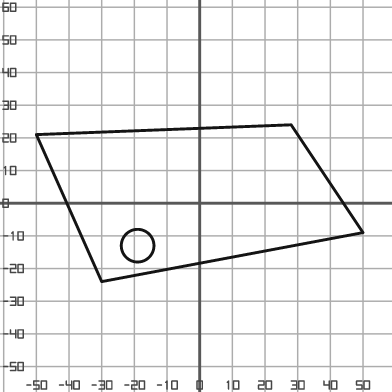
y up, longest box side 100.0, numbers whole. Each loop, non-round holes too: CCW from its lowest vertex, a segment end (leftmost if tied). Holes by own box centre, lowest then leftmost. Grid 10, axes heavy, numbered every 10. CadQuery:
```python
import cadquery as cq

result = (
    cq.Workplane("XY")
    .moveTo(-30.0, -24.0)
    .lineTo(50.0, -9.0)
    .lineTo(28.0, 24.0)
    .lineTo(-50.0, 21.0)
    .close()
    .moveTo(-19.0, -13.0)
    .circle(5.0)
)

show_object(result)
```